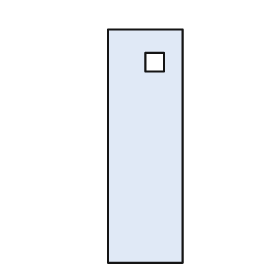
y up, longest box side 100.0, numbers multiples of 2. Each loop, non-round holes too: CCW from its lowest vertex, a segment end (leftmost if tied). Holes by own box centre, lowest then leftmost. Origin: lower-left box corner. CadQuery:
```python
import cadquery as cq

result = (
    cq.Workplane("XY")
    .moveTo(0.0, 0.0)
    .lineTo(32.0, 0.0)
    .lineTo(32.0, 100.0)
    .lineTo(0.0, 100.0)
    .close()
    .moveTo(16.0, 82.0)
    .lineTo(24.0, 82.0)
    .lineTo(24.0, 90.0)
    .lineTo(16.0, 90.0)
    .close()
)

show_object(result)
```